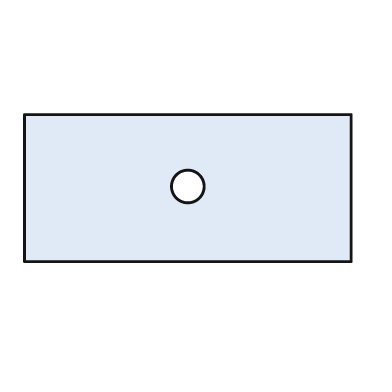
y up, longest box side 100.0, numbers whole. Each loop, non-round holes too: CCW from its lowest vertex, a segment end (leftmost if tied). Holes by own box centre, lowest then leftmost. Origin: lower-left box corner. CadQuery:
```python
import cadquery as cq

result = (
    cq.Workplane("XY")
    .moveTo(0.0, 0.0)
    .lineTo(100.0, 0.0)
    .lineTo(100.0, 45.0)
    .lineTo(0.0, 45.0)
    .close()
    .moveTo(50.0, 23.0)
    .circle(5.0)
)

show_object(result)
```